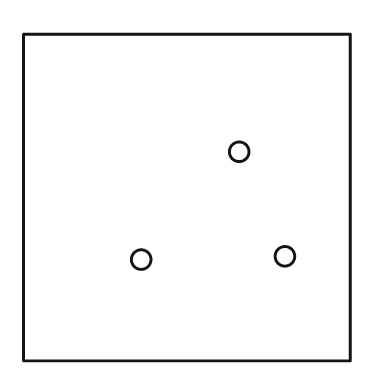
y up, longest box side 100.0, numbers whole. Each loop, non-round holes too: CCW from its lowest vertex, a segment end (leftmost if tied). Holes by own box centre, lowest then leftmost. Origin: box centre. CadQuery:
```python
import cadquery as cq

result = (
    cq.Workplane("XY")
    .moveTo(-50.0, -50.0)
    .lineTo(50.0, -50.0)
    .lineTo(50.0, 50.0)
    .lineTo(-50.0, 50.0)
    .close()
    .moveTo(-14.0, -19.0)
    .circle(3.0)
    .moveTo(30.0, -18.0)
    .circle(3.0)
    .moveTo(16.0, 14.0)
    .circle(3.0)
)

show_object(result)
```